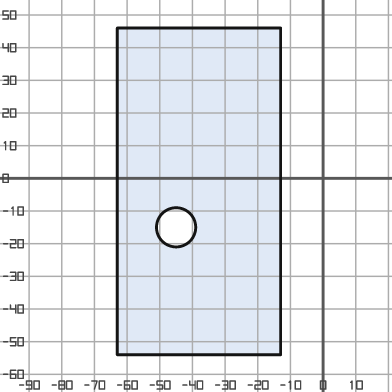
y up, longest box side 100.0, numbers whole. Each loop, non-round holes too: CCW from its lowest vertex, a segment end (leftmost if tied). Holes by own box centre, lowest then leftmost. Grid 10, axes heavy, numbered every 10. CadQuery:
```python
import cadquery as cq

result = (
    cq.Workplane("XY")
    .moveTo(-63.0, -54.0)
    .lineTo(-13.0, -54.0)
    .lineTo(-13.0, 46.0)
    .lineTo(-63.0, 46.0)
    .close()
    .moveTo(-45.0, -15.0)
    .circle(6.0)
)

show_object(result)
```